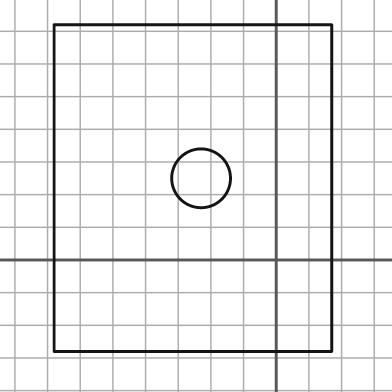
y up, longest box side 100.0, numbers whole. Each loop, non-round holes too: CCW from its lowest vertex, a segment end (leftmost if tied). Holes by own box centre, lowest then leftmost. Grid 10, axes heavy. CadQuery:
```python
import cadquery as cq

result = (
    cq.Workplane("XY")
    .moveTo(-68.0, -28.0)
    .lineTo(17.0, -28.0)
    .lineTo(17.0, 72.0)
    .lineTo(-68.0, 72.0)
    .close()
    .moveTo(-23.0, 25.0)
    .circle(9.0)
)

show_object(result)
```